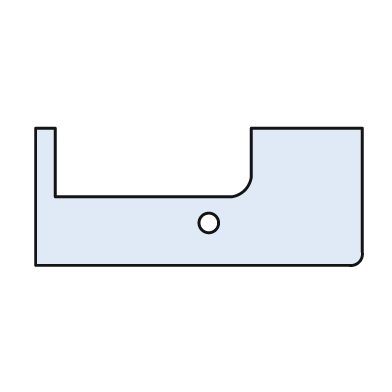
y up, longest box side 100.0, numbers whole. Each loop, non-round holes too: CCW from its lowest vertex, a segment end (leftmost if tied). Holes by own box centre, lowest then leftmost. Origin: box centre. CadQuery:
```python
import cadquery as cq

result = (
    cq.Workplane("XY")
    .moveTo(-50.0, -21.0)
    .lineTo(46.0, -21.0)
    .threePointArc((49.0, -20.0), (50.0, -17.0))
    .lineTo(50.0, 21.0)
    .lineTo(16.0, 21.0)
    .lineTo(16.0, 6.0)
    .threePointArc((14.0, 2.0), (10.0, 0.0))
    .lineTo(-44.0, 0.0)
    .lineTo(-44.0, 21.0)
    .lineTo(-50.0, 21.0)
    .close()
    .moveTo(3.0, -8.0)
    .circle(3.0)
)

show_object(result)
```